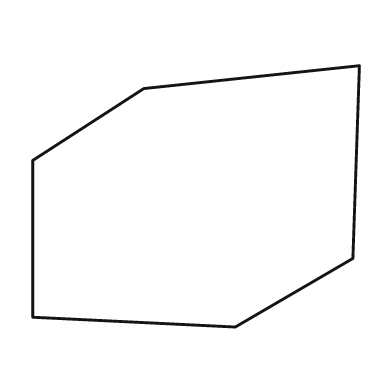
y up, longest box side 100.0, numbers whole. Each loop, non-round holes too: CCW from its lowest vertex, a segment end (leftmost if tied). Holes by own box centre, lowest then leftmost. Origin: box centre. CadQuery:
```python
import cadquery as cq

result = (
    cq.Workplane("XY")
    .moveTo(12.0, -40.0)
    .lineTo(48.0, -19.0)
    .lineTo(50.0, 40.0)
    .lineTo(-16.0, 33.0)
    .lineTo(-50.0, 11.0)
    .lineTo(-50.0, -37.0)
    .close()
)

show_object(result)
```